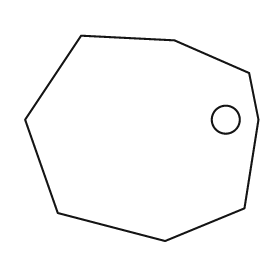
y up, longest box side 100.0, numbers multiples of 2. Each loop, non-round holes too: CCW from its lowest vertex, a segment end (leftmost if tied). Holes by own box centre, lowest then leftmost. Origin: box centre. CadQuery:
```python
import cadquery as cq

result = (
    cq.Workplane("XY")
    .moveTo(10.0, -44.0)
    .lineTo(44.0, -30.0)
    .lineTo(50.0, 8.0)
    .lineTo(46.0, 28.0)
    .lineTo(14.0, 42.0)
    .lineTo(-26.0, 44.0)
    .lineTo(-50.0, 8.0)
    .lineTo(-36.0, -32.0)
    .close()
    .moveTo(36.0, 8.0)
    .circle(6.0)
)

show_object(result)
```